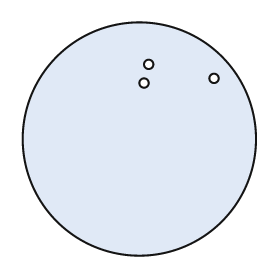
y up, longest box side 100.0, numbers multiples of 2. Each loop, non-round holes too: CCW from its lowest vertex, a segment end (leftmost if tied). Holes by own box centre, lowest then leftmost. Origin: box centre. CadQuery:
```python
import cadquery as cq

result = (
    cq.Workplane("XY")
    .moveTo(0.0, 0.0)
    .circle(50.0)
    .moveTo(2.0, 24.0)
    .circle(2.0)
    .moveTo(32.0, 26.0)
    .circle(2.0)
    .moveTo(4.0, 32.0)
    .circle(2.0)
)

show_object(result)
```